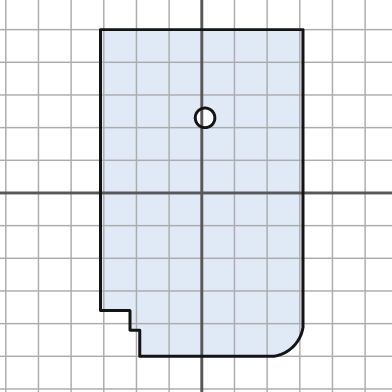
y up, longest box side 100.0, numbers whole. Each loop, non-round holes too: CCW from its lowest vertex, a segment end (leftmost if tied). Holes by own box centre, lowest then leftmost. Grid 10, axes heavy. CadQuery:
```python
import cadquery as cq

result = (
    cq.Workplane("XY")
    .moveTo(-19.0, -50.0)
    .lineTo(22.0, -50.0)
    .threePointArc((28.0, -47.0), (31.0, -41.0))
    .lineTo(31.0, 50.0)
    .lineTo(-31.0, 50.0)
    .lineTo(-31.0, -36.0)
    .lineTo(-22.0, -36.0)
    .lineTo(-22.0, -42.0)
    .lineTo(-19.0, -42.0)
    .close()
    .moveTo(1.0, 23.0)
    .circle(3.0)
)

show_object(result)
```